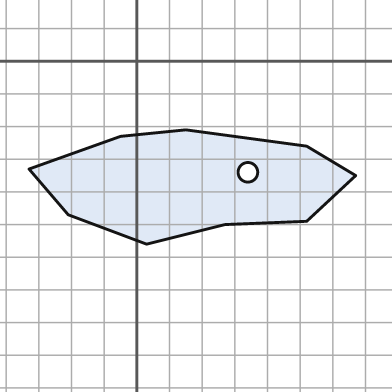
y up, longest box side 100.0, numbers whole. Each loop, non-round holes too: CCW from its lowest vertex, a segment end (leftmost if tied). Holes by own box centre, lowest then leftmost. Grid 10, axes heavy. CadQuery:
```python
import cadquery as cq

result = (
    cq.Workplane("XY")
    .moveTo(3.0, -56.0)
    .lineTo(27.0, -50.0)
    .lineTo(52.0, -49.0)
    .lineTo(67.0, -35.0)
    .lineTo(52.0, -26.0)
    .lineTo(15.0, -21.0)
    .lineTo(-5.0, -23.0)
    .lineTo(-33.0, -33.0)
    .lineTo(-21.0, -47.0)
    .close()
    .moveTo(34.0, -34.0)
    .circle(3.0)
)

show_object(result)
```